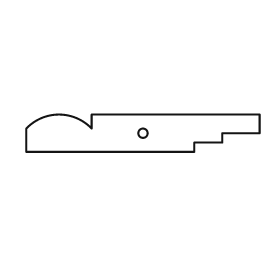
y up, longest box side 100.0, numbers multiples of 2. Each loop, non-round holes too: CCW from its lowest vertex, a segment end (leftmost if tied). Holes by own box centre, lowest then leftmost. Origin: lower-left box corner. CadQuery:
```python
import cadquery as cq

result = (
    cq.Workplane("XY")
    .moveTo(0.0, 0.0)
    .lineTo(72.0, 0.0)
    .lineTo(72.0, 4.0)
    .lineTo(84.0, 4.0)
    .lineTo(84.0, 8.0)
    .lineTo(100.0, 8.0)
    .lineTo(100.0, 16.0)
    .lineTo(28.0, 16.0)
    .lineTo(28.0, 10.0)
    .threePointArc((14.0, 16.0), (0.0, 10.0))
    .close()
    .moveTo(50.0, 8.0)
    .circle(2.0)
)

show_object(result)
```